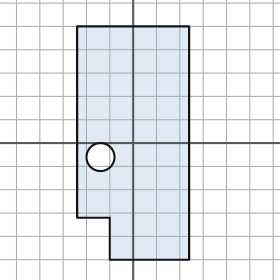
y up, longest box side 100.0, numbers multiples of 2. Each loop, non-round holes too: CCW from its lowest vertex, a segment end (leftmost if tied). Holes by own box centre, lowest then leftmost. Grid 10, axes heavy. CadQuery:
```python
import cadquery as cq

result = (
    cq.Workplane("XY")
    .moveTo(-10.0, -50.0)
    .lineTo(24.0, -50.0)
    .lineTo(24.0, 50.0)
    .lineTo(-24.0, 50.0)
    .lineTo(-24.0, -32.0)
    .lineTo(-10.0, -32.0)
    .close()
    .moveTo(-14.0, -6.0)
    .circle(6.0)
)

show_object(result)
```